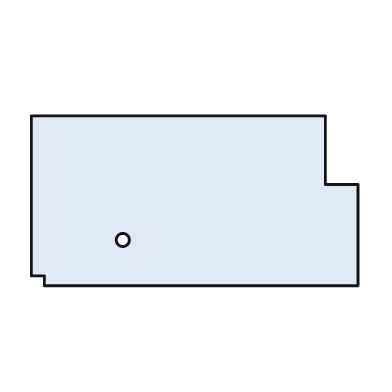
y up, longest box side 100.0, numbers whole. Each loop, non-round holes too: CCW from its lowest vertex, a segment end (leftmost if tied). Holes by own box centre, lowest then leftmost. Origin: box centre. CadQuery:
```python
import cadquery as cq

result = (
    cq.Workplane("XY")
    .moveTo(-46.0, -26.0)
    .lineTo(50.0, -26.0)
    .lineTo(50.0, 5.0)
    .lineTo(40.0, 5.0)
    .lineTo(40.0, 26.0)
    .lineTo(-50.0, 26.0)
    .lineTo(-50.0, -23.0)
    .lineTo(-46.0, -23.0)
    .close()
    .moveTo(-22.0, -12.0)
    .circle(2.0)
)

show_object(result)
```